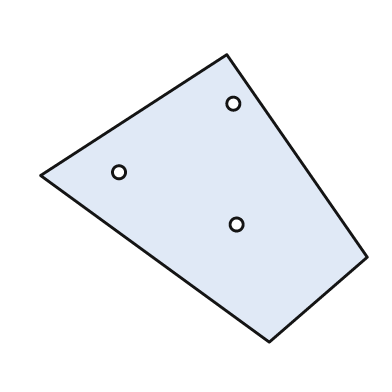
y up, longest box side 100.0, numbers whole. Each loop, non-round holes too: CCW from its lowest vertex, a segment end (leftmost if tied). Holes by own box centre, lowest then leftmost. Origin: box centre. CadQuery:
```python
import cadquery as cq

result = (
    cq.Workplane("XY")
    .moveTo(20.0, -44.0)
    .lineTo(50.0, -18.0)
    .lineTo(7.0, 44.0)
    .lineTo(-50.0, 7.0)
    .close()
    .moveTo(10.0, -8.0)
    .circle(2.0)
    .moveTo(-26.0, 8.0)
    .circle(2.0)
    .moveTo(9.0, 29.0)
    .circle(2.0)
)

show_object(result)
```